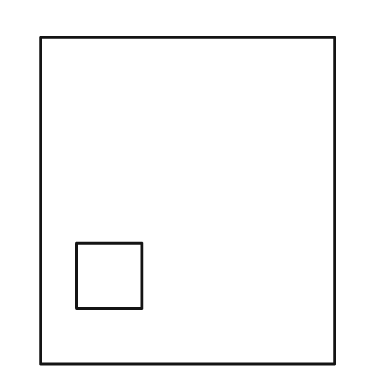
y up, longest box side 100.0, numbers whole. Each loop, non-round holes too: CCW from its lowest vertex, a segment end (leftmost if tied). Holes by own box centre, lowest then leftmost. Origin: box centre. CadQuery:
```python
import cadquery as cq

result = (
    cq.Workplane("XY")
    .moveTo(-45.0, -50.0)
    .lineTo(45.0, -50.0)
    .lineTo(45.0, 50.0)
    .lineTo(-45.0, 50.0)
    .close()
    .moveTo(-34.0, -33.0)
    .lineTo(-14.0, -33.0)
    .lineTo(-14.0, -13.0)
    .lineTo(-34.0, -13.0)
    .close()
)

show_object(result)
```